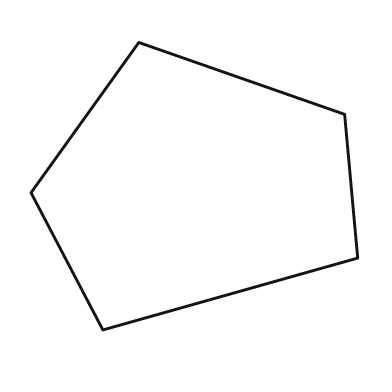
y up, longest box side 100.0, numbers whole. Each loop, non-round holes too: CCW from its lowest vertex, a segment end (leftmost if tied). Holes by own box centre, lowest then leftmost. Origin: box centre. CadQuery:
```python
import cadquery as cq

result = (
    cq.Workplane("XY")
    .moveTo(-28.0, -44.0)
    .lineTo(50.0, -22.0)
    .lineTo(46.0, 22.0)
    .lineTo(-17.0, 44.0)
    .lineTo(-50.0, -2.0)
    .close()
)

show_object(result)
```